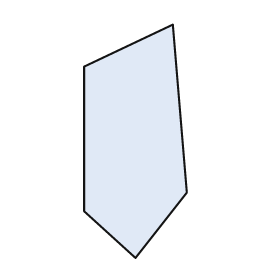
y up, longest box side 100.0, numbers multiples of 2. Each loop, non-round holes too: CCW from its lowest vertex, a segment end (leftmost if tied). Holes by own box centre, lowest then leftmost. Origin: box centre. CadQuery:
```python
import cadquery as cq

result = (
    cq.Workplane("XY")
    .moveTo(0.0, -50.0)
    .lineTo(22.0, -22.0)
    .lineTo(16.0, 50.0)
    .lineTo(-22.0, 32.0)
    .lineTo(-22.0, -30.0)
    .close()
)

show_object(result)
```